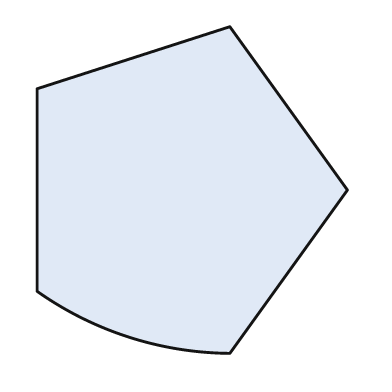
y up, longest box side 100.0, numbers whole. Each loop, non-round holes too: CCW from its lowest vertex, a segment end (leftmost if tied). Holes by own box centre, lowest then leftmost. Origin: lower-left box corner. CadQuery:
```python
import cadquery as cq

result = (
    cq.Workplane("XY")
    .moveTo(59.0, 0.0)
    .lineTo(95.0, 50.0)
    .lineTo(59.0, 100.0)
    .lineTo(0.0, 81.0)
    .lineTo(0.0, 19.0)
    .threePointArc((28.0, 5.0), (59.0, 0.0))
    .close()
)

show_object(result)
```